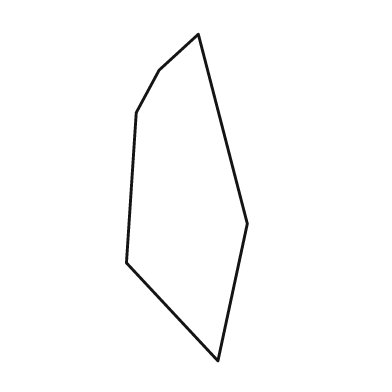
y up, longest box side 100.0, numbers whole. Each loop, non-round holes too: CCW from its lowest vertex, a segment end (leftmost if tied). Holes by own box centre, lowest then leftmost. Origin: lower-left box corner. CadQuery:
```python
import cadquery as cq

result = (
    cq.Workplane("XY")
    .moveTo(28.0, 0.0)
    .lineTo(37.0, 42.0)
    .lineTo(22.0, 100.0)
    .lineTo(10.0, 89.0)
    .lineTo(3.0, 76.0)
    .lineTo(0.0, 30.0)
    .close()
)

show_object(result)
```